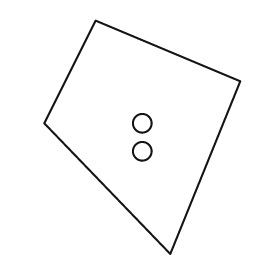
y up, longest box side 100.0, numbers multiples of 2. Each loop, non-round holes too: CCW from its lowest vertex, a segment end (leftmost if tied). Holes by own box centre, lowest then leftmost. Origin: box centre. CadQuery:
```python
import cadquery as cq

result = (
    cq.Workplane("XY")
    .moveTo(12.0, -50.0)
    .lineTo(42.0, 24.0)
    .lineTo(-20.0, 50.0)
    .lineTo(-42.0, 6.0)
    .close()
    .moveTo(0.0, -6.0)
    .circle(4.0)
    .moveTo(0.0, 6.0)
    .circle(4.0)
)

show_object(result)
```